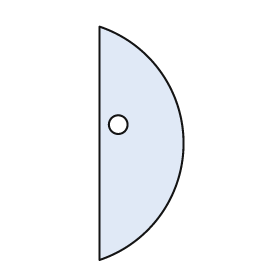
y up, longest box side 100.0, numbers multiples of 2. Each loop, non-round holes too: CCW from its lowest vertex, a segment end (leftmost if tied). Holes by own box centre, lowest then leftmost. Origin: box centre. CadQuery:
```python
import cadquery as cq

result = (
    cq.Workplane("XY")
    .moveTo(-18.0, -50.0)
    .threePointArc((18.0, 0.0), (-18.0, 50.0))
    .close()
    .moveTo(-10.0, 8.0)
    .circle(4.0)
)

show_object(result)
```